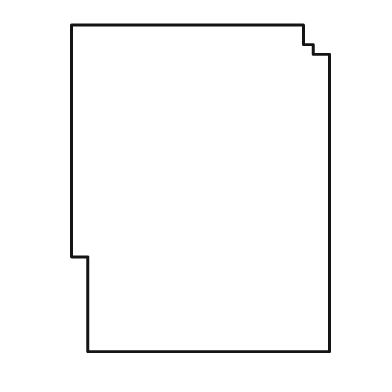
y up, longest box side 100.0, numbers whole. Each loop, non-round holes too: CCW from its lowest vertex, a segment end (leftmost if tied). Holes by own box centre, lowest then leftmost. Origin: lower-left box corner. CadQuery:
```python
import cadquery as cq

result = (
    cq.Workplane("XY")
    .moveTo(5.0, 0.0)
    .lineTo(79.0, 0.0)
    .lineTo(79.0, 91.0)
    .lineTo(74.0, 91.0)
    .lineTo(74.0, 94.0)
    .lineTo(71.0, 94.0)
    .lineTo(71.0, 100.0)
    .lineTo(0.0, 100.0)
    .lineTo(0.0, 29.0)
    .lineTo(5.0, 29.0)
    .close()
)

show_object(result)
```